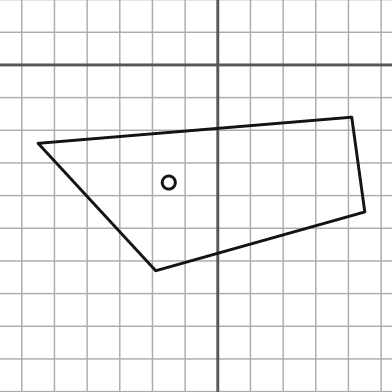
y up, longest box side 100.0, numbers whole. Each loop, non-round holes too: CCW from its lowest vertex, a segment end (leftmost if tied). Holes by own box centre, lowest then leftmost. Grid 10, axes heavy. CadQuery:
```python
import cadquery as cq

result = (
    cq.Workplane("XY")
    .moveTo(-19.0, -63.0)
    .lineTo(45.0, -45.0)
    .lineTo(41.0, -16.0)
    .lineTo(-55.0, -24.0)
    .close()
    .moveTo(-15.0, -36.0)
    .circle(2.0)
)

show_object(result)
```